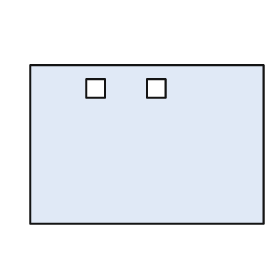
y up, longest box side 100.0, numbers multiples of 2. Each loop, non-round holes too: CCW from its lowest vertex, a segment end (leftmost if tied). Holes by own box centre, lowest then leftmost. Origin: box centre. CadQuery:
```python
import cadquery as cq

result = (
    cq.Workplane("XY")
    .moveTo(-50.0, -34.0)
    .lineTo(50.0, -34.0)
    .lineTo(50.0, 34.0)
    .lineTo(-50.0, 34.0)
    .close()
    .moveTo(-26.0, 20.0)
    .lineTo(-18.0, 20.0)
    .lineTo(-18.0, 28.0)
    .lineTo(-26.0, 28.0)
    .close()
    .moveTo(0.0, 20.0)
    .lineTo(8.0, 20.0)
    .lineTo(8.0, 28.0)
    .lineTo(0.0, 28.0)
    .close()
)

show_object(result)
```